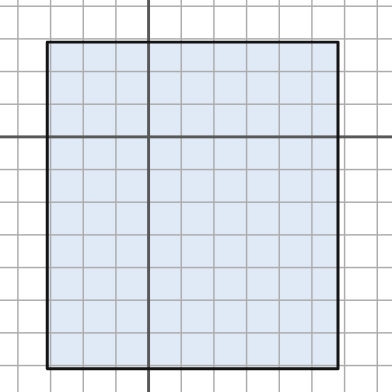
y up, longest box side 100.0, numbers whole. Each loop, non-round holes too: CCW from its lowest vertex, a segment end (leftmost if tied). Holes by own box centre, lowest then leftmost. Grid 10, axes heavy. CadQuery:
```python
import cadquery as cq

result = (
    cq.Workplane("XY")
    .moveTo(-31.0, -71.0)
    .lineTo(58.0, -71.0)
    .lineTo(58.0, 29.0)
    .lineTo(-31.0, 29.0)
    .close()
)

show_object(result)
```